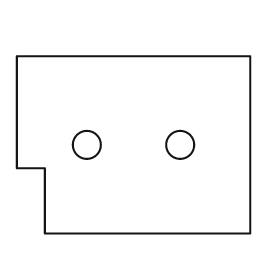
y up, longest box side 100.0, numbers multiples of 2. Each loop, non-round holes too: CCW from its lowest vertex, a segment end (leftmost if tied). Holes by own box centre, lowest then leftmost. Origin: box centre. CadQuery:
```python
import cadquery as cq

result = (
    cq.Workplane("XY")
    .moveTo(-38.0, -38.0)
    .lineTo(50.0, -38.0)
    .lineTo(50.0, 38.0)
    .lineTo(-50.0, 38.0)
    .lineTo(-50.0, -10.0)
    .lineTo(-38.0, -10.0)
    .close()
    .moveTo(-20.0, 0.0)
    .circle(6.0)
    .moveTo(20.0, 0.0)
    .circle(6.0)
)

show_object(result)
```